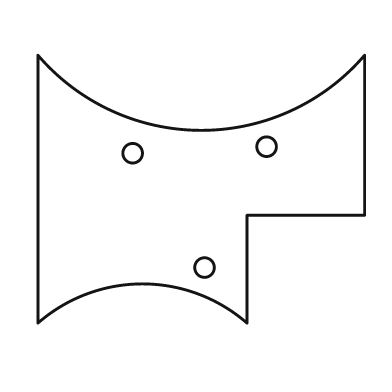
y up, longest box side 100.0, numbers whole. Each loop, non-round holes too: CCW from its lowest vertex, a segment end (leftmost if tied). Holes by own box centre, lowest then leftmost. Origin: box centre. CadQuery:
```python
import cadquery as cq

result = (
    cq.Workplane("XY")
    .moveTo(-50.0, -41.0)
    .threePointArc((-18.0, -29.0), (14.0, -41.0))
    .lineTo(14.0, -8.0)
    .lineTo(50.0, -8.0)
    .lineTo(50.0, 41.0)
    .threePointArc((0.0, 18.0), (-50.0, 41.0))
    .close()
    .moveTo(1.0, -24.0)
    .circle(3.0)
    .moveTo(-21.0, 11.0)
    .circle(3.0)
    .moveTo(20.0, 13.0)
    .circle(3.0)
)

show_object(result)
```